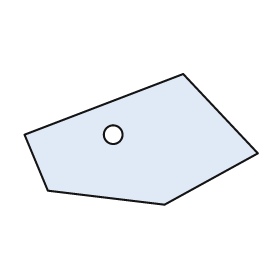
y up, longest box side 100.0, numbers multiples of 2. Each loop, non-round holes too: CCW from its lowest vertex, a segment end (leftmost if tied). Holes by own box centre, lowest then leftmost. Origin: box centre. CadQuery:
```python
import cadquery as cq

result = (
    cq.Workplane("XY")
    .moveTo(10.0, -28.0)
    .lineTo(50.0, -6.0)
    .lineTo(18.0, 28.0)
    .lineTo(-50.0, 2.0)
    .lineTo(-40.0, -22.0)
    .close()
    .moveTo(-12.0, 2.0)
    .circle(4.0)
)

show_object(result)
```